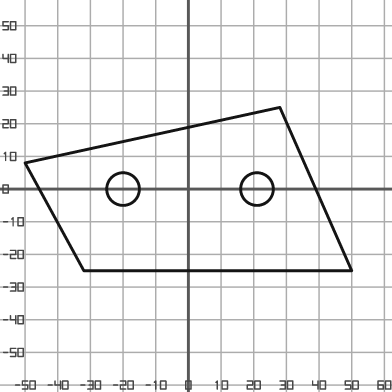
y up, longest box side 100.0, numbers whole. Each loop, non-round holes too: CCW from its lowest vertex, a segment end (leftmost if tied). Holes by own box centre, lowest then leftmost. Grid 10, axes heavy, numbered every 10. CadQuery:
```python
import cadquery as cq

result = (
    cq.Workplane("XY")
    .moveTo(-32.0, -25.0)
    .lineTo(50.0, -25.0)
    .lineTo(28.0, 25.0)
    .lineTo(-50.0, 8.0)
    .close()
    .moveTo(-20.0, 0.0)
    .circle(5.0)
    .moveTo(21.0, 0.0)
    .circle(5.0)
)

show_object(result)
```